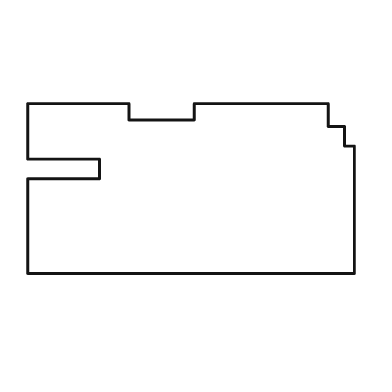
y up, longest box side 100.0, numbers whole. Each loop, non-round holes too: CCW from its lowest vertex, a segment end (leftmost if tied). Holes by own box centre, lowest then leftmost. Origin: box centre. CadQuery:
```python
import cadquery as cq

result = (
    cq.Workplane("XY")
    .moveTo(-50.0, -26.0)
    .lineTo(50.0, -26.0)
    .lineTo(50.0, 13.0)
    .lineTo(47.0, 13.0)
    .lineTo(47.0, 19.0)
    .lineTo(42.0, 19.0)
    .lineTo(42.0, 26.0)
    .lineTo(1.0, 26.0)
    .lineTo(1.0, 21.0)
    .lineTo(-19.0, 21.0)
    .lineTo(-19.0, 26.0)
    .lineTo(-50.0, 26.0)
    .lineTo(-50.0, 9.0)
    .lineTo(-28.0, 9.0)
    .lineTo(-28.0, 3.0)
    .lineTo(-50.0, 3.0)
    .close()
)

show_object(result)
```